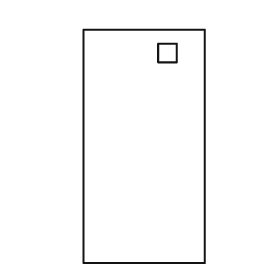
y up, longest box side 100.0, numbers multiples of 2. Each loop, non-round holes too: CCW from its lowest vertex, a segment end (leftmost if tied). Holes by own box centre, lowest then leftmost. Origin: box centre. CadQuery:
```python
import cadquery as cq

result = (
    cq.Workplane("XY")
    .moveTo(-26.0, -50.0)
    .lineTo(26.0, -50.0)
    .lineTo(26.0, 50.0)
    .lineTo(-26.0, 50.0)
    .close()
    .moveTo(6.0, 36.0)
    .lineTo(14.0, 36.0)
    .lineTo(14.0, 44.0)
    .lineTo(6.0, 44.0)
    .close()
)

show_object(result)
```